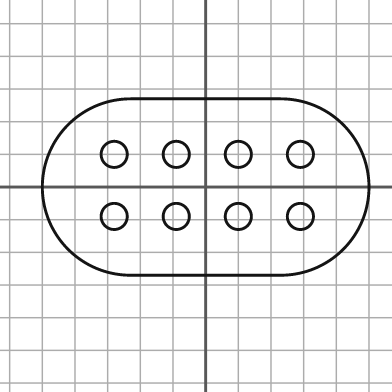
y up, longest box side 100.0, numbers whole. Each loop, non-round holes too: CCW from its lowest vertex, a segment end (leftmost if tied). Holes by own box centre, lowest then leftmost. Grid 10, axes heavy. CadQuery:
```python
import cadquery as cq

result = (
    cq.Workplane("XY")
    .moveTo(-23.0, -27.0)
    .lineTo(23.0, -27.0)
    .threePointArc((50.0, 0.0), (23.0, 27.0))
    .lineTo(-23.0, 27.0)
    .threePointArc((-50.0, 0.0), (-23.0, -27.0))
    .close()
    .moveTo(-28.0, -9.0)
    .circle(4.0)
    .moveTo(-9.0, -9.0)
    .circle(4.0)
    .moveTo(10.0, -9.0)
    .circle(4.0)
    .moveTo(29.0, -9.0)
    .circle(4.0)
    .moveTo(-28.0, 10.0)
    .circle(4.0)
    .moveTo(-9.0, 10.0)
    .circle(4.0)
    .moveTo(10.0, 10.0)
    .circle(4.0)
    .moveTo(29.0, 10.0)
    .circle(4.0)
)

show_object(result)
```